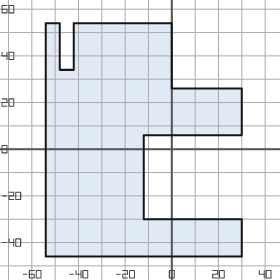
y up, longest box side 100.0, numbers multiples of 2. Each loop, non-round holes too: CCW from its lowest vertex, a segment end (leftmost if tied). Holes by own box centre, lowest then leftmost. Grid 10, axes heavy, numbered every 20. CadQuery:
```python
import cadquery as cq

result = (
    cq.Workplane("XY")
    .moveTo(-54.0, -46.0)
    .lineTo(30.0, -46.0)
    .lineTo(30.0, -30.0)
    .lineTo(-12.0, -30.0)
    .lineTo(-12.0, 6.0)
    .lineTo(30.0, 6.0)
    .lineTo(30.0, 26.0)
    .lineTo(0.0, 26.0)
    .lineTo(0.0, 54.0)
    .lineTo(-42.0, 54.0)
    .lineTo(-42.0, 34.0)
    .lineTo(-48.0, 34.0)
    .lineTo(-48.0, 54.0)
    .lineTo(-54.0, 54.0)
    .close()
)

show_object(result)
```